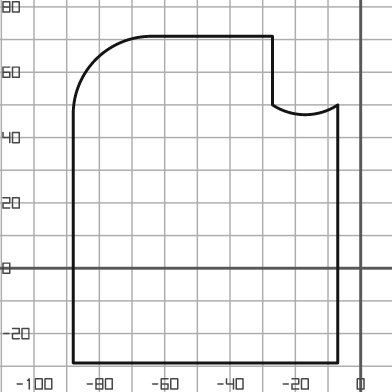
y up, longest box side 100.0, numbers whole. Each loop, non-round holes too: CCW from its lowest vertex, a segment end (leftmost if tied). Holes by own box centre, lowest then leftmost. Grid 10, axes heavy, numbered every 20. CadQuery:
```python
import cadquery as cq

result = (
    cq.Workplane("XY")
    .moveTo(-88.0, -29.0)
    .lineTo(-7.0, -29.0)
    .lineTo(-7.0, 50.0)
    .threePointArc((-17.0, 47.0), (-27.0, 50.0))
    .lineTo(-27.0, 71.0)
    .lineTo(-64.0, 71.0)
    .threePointArc((-81.0, 64.0), (-88.0, 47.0))
    .close()
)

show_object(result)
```